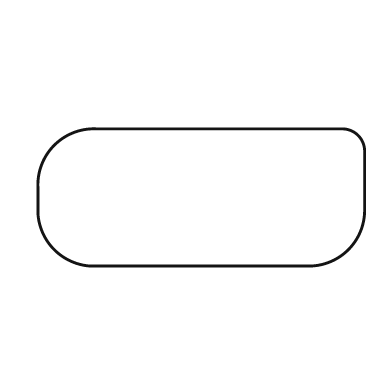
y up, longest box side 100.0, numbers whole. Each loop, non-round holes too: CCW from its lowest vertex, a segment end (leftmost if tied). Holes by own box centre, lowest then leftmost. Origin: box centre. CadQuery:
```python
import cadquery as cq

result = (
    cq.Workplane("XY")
    .moveTo(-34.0, -21.0)
    .lineTo(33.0, -21.0)
    .threePointArc((45.0, -16.0), (50.0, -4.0))
    .lineTo(50.0, 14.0)
    .threePointArc((48.0, 19.0), (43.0, 21.0))
    .lineTo(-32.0, 21.0)
    .threePointArc((-45.0, 16.0), (-50.0, 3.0))
    .lineTo(-50.0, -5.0)
    .threePointArc((-45.0, -16.0), (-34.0, -21.0))
    .close()
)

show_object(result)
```